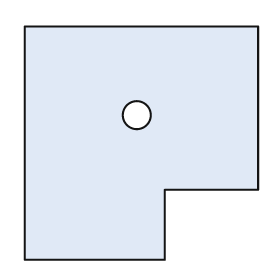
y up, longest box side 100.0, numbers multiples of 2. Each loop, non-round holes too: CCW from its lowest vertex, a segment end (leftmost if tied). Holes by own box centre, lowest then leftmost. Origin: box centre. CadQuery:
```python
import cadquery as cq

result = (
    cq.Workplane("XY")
    .moveTo(-50.0, -50.0)
    .lineTo(10.0, -50.0)
    .lineTo(10.0, -20.0)
    .lineTo(50.0, -20.0)
    .lineTo(50.0, 50.0)
    .lineTo(-50.0, 50.0)
    .close()
    .moveTo(-2.0, 12.0)
    .circle(6.0)
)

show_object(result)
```